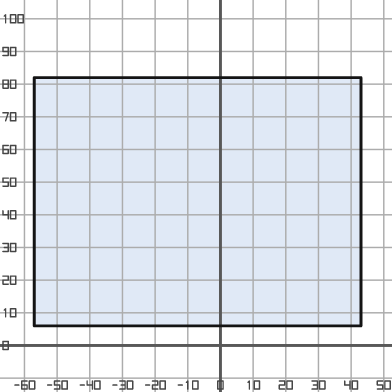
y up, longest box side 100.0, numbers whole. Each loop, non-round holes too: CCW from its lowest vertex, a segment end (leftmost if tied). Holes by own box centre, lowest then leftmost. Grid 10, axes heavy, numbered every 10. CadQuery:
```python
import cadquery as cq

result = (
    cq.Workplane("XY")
    .moveTo(-57.0, 6.0)
    .lineTo(43.0, 6.0)
    .lineTo(43.0, 82.0)
    .lineTo(-57.0, 82.0)
    .close()
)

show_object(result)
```